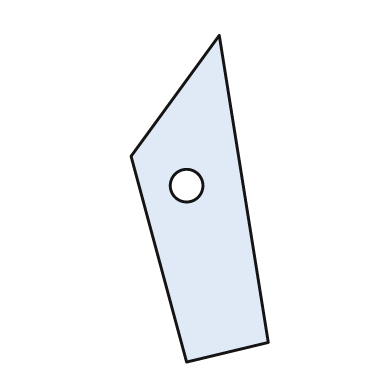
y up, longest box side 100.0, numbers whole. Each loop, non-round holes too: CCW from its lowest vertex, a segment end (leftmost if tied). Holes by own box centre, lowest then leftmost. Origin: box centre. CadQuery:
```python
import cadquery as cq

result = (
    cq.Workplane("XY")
    .moveTo(-4.0, -50.0)
    .lineTo(21.0, -44.0)
    .lineTo(6.0, 50.0)
    .lineTo(-21.0, 13.0)
    .close()
    .moveTo(-4.0, 4.0)
    .circle(5.0)
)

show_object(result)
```